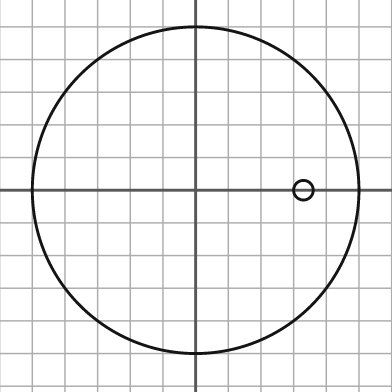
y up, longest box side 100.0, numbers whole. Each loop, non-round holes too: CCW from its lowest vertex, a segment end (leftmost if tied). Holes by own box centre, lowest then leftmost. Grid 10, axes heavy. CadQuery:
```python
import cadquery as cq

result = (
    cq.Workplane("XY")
    .moveTo(0.0, 0.0)
    .circle(50.0)
    .moveTo(33.0, 0.0)
    .circle(3.0)
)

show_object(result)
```